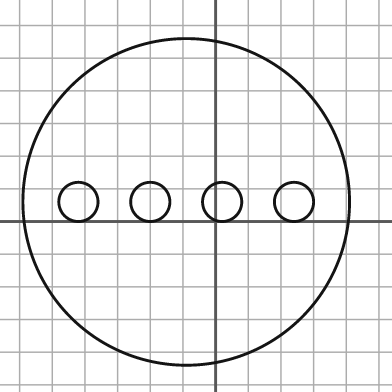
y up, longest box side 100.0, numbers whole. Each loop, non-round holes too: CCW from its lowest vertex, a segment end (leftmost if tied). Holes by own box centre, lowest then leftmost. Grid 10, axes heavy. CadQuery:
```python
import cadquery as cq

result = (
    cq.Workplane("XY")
    .moveTo(-9.0, 6.0)
    .circle(50.0)
    .moveTo(-42.0, 6.0)
    .circle(6.0)
    .moveTo(-20.0, 6.0)
    .circle(6.0)
    .moveTo(2.0, 6.0)
    .circle(6.0)
    .moveTo(24.0, 6.0)
    .circle(6.0)
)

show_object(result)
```